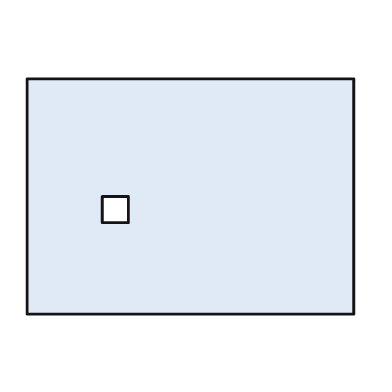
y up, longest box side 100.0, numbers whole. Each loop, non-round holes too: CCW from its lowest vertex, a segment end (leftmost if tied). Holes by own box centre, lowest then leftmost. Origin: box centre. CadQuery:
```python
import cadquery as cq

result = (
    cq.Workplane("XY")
    .moveTo(-50.0, -36.0)
    .lineTo(50.0, -36.0)
    .lineTo(50.0, 36.0)
    .lineTo(-50.0, 36.0)
    .close()
    .moveTo(-27.0, -8.0)
    .lineTo(-19.0, -8.0)
    .lineTo(-19.0, 0.0)
    .lineTo(-27.0, 0.0)
    .close()
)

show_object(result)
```